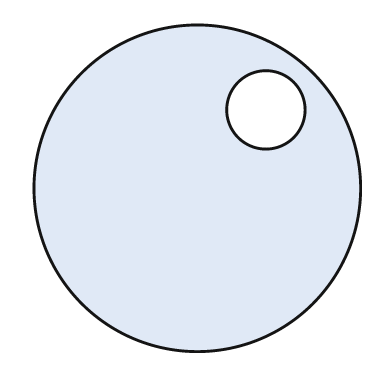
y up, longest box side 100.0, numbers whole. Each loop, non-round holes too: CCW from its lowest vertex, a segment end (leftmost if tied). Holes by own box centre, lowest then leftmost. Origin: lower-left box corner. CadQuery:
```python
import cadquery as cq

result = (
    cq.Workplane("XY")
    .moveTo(50.0, 50.0)
    .circle(50.0)
    .moveTo(71.0, 74.0)
    .circle(12.0)
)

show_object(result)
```